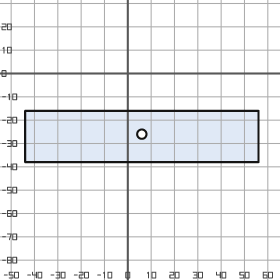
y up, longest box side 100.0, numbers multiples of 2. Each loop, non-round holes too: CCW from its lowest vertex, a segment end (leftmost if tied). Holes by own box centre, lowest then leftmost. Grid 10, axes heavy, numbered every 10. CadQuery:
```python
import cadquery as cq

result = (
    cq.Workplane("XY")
    .moveTo(-44.0, -38.0)
    .lineTo(56.0, -38.0)
    .lineTo(56.0, -16.0)
    .lineTo(-44.0, -16.0)
    .close()
    .moveTo(6.0, -26.0)
    .circle(2.0)
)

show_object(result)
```